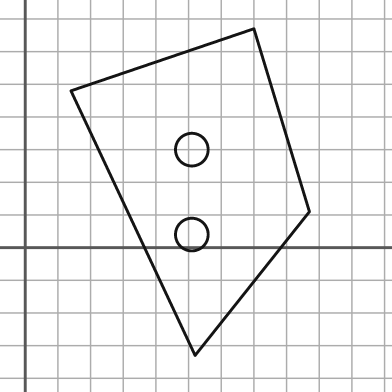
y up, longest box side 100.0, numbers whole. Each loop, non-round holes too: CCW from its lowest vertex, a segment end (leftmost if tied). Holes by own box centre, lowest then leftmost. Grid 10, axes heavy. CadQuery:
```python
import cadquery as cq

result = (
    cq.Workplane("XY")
    .moveTo(52.0, -33.0)
    .lineTo(87.0, 11.0)
    .lineTo(70.0, 67.0)
    .lineTo(14.0, 48.0)
    .close()
    .moveTo(51.0, 4.0)
    .circle(5.0)
    .moveTo(51.0, 30.0)
    .circle(5.0)
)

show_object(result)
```